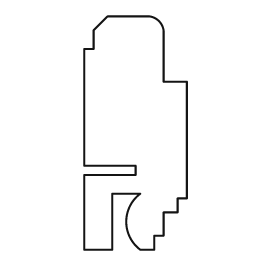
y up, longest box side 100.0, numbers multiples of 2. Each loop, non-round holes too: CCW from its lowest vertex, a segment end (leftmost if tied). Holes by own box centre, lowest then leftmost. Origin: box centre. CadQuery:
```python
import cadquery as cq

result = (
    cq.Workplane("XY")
    .moveTo(-22.0, -50.0)
    .lineTo(-10.0, -50.0)
    .lineTo(-10.0, -26.0)
    .lineTo(2.0, -26.0)
    .threePointArc((-4.0, -38.0), (2.0, -50.0))
    .lineTo(8.0, -50.0)
    .lineTo(8.0, -44.0)
    .lineTo(12.0, -44.0)
    .lineTo(12.0, -34.0)
    .lineTo(18.0, -34.0)
    .lineTo(18.0, -28.0)
    .lineTo(22.0, -28.0)
    .lineTo(22.0, 22.0)
    .lineTo(12.0, 22.0)
    .lineTo(12.0, 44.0)
    .threePointArc((10.0, 48.0), (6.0, 50.0))
    .lineTo(-12.0, 50.0)
    .lineTo(-18.0, 44.0)
    .lineTo(-18.0, 36.0)
    .lineTo(-22.0, 36.0)
    .lineTo(-22.0, -14.0)
    .lineTo(0.0, -14.0)
    .lineTo(0.0, -18.0)
    .lineTo(-22.0, -18.0)
    .close()
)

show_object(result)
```